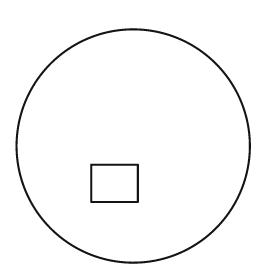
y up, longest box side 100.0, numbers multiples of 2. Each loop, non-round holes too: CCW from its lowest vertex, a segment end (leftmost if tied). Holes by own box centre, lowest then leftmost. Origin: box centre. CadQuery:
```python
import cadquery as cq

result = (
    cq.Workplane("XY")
    .moveTo(0.0, 0.0)
    .circle(50.0)
    .moveTo(-18.0, -24.0)
    .lineTo(2.0, -24.0)
    .lineTo(2.0, -8.0)
    .lineTo(-18.0, -8.0)
    .close()
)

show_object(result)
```